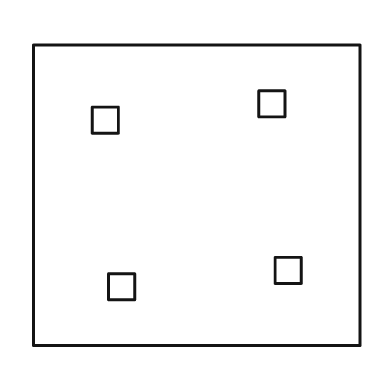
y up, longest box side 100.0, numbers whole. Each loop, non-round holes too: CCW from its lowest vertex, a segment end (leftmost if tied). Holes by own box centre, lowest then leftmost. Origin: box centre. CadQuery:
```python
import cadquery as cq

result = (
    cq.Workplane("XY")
    .moveTo(-50.0, -46.0)
    .lineTo(50.0, -46.0)
    .lineTo(50.0, 46.0)
    .lineTo(-50.0, 46.0)
    .close()
    .moveTo(-27.0, -32.0)
    .lineTo(-19.0, -32.0)
    .lineTo(-19.0, -24.0)
    .lineTo(-27.0, -24.0)
    .close()
    .moveTo(24.0, -27.0)
    .lineTo(32.0, -27.0)
    .lineTo(32.0, -19.0)
    .lineTo(24.0, -19.0)
    .close()
    .moveTo(-32.0, 19.0)
    .lineTo(-24.0, 19.0)
    .lineTo(-24.0, 27.0)
    .lineTo(-32.0, 27.0)
    .close()
    .moveTo(19.0, 24.0)
    .lineTo(27.0, 24.0)
    .lineTo(27.0, 32.0)
    .lineTo(19.0, 32.0)
    .close()
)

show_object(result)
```